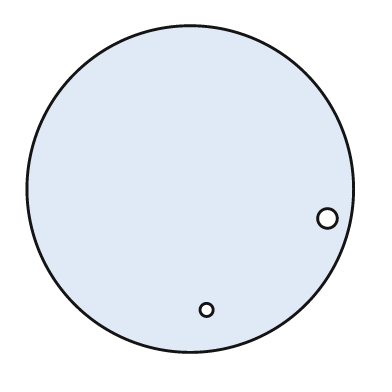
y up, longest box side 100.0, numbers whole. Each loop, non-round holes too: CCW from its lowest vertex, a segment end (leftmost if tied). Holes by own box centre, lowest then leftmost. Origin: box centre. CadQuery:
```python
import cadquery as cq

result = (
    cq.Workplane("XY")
    .moveTo(0.0, 0.0)
    .circle(50.0)
    .moveTo(5.0, -37.0)
    .circle(2.0)
    .moveTo(42.0, -9.0)
    .circle(3.0)
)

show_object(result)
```